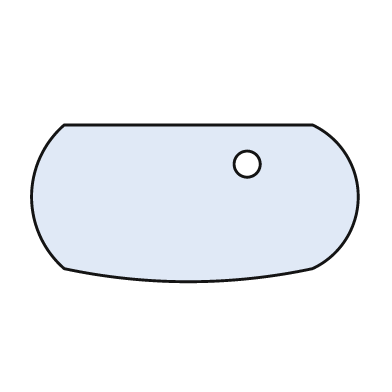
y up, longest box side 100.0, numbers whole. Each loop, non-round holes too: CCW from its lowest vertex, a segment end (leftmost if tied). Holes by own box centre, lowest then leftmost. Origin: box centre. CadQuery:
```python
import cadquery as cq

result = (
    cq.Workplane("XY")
    .moveTo(-40.0, -20.0)
    .threePointArc((-2.0, -24.0), (36.0, -20.0))
    .threePointArc((50.0, 2.0), (36.0, 24.0))
    .lineTo(-40.0, 24.0)
    .threePointArc((-50.0, 2.0), (-40.0, -20.0))
    .close()
    .moveTo(16.0, 12.0)
    .circle(4.0)
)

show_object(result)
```